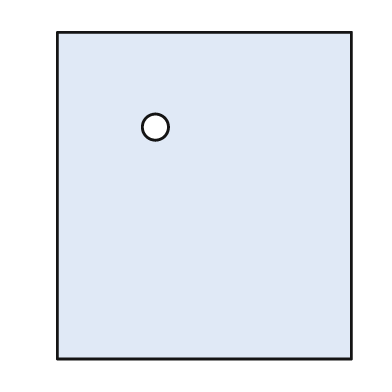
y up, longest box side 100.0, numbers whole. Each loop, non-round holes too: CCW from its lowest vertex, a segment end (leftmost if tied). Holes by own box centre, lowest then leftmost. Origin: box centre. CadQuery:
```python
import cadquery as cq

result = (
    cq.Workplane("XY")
    .moveTo(-45.0, -50.0)
    .lineTo(45.0, -50.0)
    .lineTo(45.0, 50.0)
    .lineTo(-45.0, 50.0)
    .close()
    .moveTo(-15.0, 21.0)
    .circle(4.0)
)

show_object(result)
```